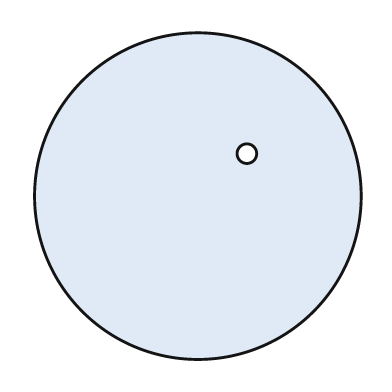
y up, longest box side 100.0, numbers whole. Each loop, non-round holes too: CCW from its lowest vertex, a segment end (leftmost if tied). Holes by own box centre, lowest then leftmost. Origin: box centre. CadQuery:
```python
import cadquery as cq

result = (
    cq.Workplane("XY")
    .moveTo(0.0, 0.0)
    .circle(50.0)
    .moveTo(15.0, 13.0)
    .circle(3.0)
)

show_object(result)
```